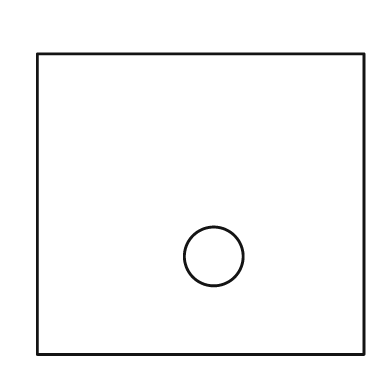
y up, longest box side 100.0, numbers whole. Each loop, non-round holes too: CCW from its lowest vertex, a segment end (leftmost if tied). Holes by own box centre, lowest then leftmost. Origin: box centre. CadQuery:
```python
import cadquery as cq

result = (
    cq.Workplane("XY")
    .moveTo(-50.0, -46.0)
    .lineTo(50.0, -46.0)
    .lineTo(50.0, 46.0)
    .lineTo(-50.0, 46.0)
    .close()
    .moveTo(4.0, -16.0)
    .circle(9.0)
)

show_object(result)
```